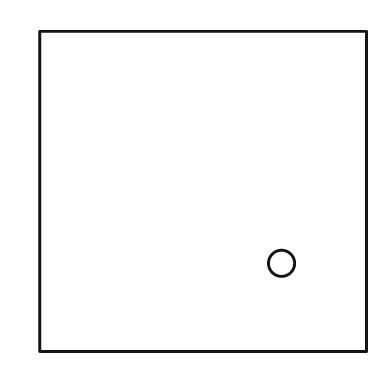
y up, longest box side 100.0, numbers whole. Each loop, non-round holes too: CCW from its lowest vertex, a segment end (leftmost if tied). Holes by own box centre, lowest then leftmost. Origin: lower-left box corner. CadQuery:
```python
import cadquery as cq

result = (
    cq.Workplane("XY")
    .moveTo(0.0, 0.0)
    .lineTo(100.0, 0.0)
    .lineTo(100.0, 98.0)
    .lineTo(0.0, 98.0)
    .close()
    .moveTo(74.0, 27.0)
    .circle(4.0)
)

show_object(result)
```